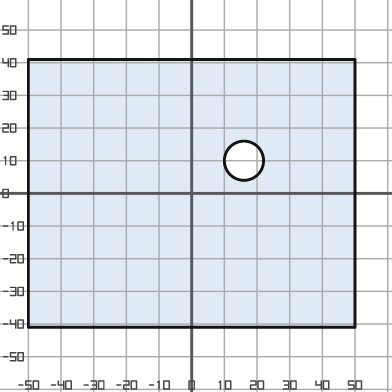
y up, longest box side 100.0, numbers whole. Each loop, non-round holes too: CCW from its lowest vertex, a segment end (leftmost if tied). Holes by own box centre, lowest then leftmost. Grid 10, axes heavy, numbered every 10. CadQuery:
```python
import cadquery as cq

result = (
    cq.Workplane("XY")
    .moveTo(-50.0, -41.0)
    .lineTo(50.0, -41.0)
    .lineTo(50.0, 41.0)
    .lineTo(-50.0, 41.0)
    .close()
    .moveTo(16.0, 10.0)
    .circle(6.0)
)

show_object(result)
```